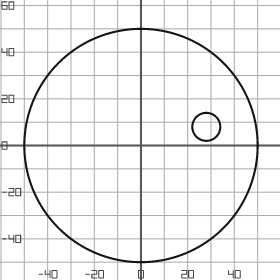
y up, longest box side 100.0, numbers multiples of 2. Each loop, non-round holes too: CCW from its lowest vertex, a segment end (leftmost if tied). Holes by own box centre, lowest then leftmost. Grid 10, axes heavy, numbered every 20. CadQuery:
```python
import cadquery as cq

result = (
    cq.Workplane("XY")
    .moveTo(0.0, 0.0)
    .circle(50.0)
    .moveTo(28.0, 8.0)
    .circle(6.0)
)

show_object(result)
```